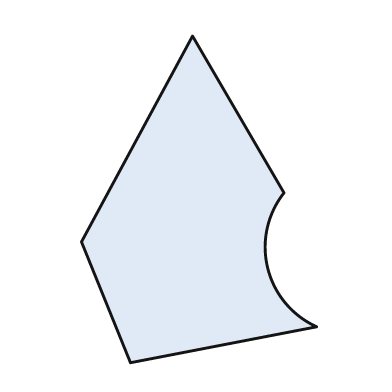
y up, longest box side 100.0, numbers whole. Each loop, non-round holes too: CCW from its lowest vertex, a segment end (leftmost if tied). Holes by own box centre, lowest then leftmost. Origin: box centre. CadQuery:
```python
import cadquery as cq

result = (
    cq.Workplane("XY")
    .moveTo(-21.0, -50.0)
    .lineTo(36.0, -39.0)
    .threePointArc((21.0, -21.0), (26.0, 2.0))
    .lineTo(-2.0, 50.0)
    .lineTo(-36.0, -13.0)
    .close()
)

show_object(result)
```